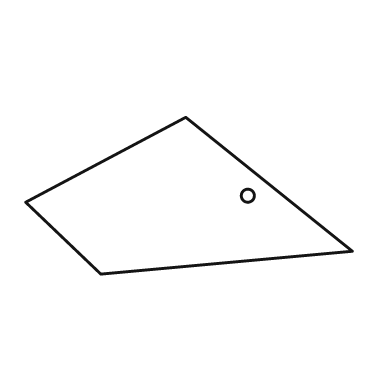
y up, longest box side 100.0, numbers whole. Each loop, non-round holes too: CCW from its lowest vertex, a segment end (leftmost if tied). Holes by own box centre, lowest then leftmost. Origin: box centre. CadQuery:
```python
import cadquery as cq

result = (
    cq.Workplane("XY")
    .moveTo(-27.0, -24.0)
    .lineTo(50.0, -17.0)
    .lineTo(-1.0, 24.0)
    .lineTo(-50.0, -2.0)
    .close()
    .moveTo(18.0, 0.0)
    .circle(2.0)
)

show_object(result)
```